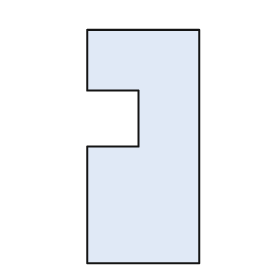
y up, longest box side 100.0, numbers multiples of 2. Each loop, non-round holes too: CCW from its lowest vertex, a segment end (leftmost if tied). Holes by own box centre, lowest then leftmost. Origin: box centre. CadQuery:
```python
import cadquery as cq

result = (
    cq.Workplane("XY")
    .moveTo(-24.0, -50.0)
    .lineTo(24.0, -50.0)
    .lineTo(24.0, 50.0)
    .lineTo(-24.0, 50.0)
    .lineTo(-24.0, 24.0)
    .lineTo(-2.0, 24.0)
    .lineTo(-2.0, 0.0)
    .lineTo(-24.0, 0.0)
    .close()
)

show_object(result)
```